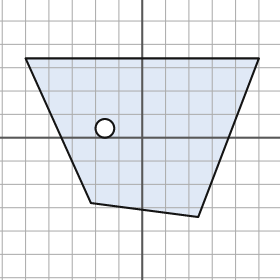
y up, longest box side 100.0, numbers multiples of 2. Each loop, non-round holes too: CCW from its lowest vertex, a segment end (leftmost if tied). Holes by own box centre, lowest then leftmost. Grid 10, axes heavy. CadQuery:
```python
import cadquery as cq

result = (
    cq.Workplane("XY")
    .moveTo(24.0, -34.0)
    .lineTo(50.0, 34.0)
    .lineTo(-50.0, 34.0)
    .lineTo(-22.0, -28.0)
    .close()
    .moveTo(-16.0, 4.0)
    .circle(4.0)
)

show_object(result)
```